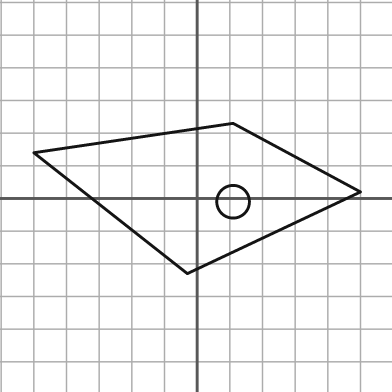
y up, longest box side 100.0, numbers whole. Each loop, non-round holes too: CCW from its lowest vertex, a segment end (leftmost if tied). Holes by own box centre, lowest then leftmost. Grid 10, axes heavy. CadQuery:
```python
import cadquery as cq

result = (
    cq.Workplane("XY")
    .moveTo(-3.0, -23.0)
    .lineTo(50.0, 2.0)
    .lineTo(11.0, 23.0)
    .lineTo(-50.0, 14.0)
    .close()
    .moveTo(11.0, -1.0)
    .circle(5.0)
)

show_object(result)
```